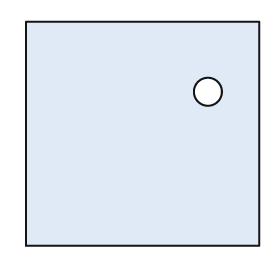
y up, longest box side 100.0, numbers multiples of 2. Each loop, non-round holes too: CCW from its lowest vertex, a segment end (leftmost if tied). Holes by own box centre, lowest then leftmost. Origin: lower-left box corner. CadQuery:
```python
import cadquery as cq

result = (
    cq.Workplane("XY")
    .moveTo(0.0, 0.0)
    .lineTo(100.0, 0.0)
    .lineTo(100.0, 96.0)
    .lineTo(0.0, 96.0)
    .close()
    .moveTo(78.0, 66.0)
    .circle(6.0)
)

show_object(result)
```